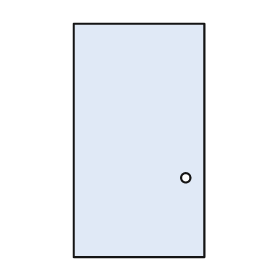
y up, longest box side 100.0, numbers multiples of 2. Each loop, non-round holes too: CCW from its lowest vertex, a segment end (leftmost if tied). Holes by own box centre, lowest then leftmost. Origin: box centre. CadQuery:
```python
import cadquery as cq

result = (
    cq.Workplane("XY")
    .moveTo(-28.0, -50.0)
    .lineTo(28.0, -50.0)
    .lineTo(28.0, 50.0)
    .lineTo(-28.0, 50.0)
    .close()
    .moveTo(20.0, -16.0)
    .circle(2.0)
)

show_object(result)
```